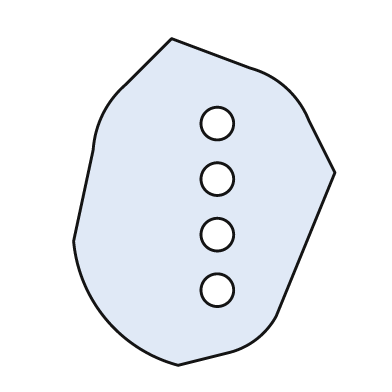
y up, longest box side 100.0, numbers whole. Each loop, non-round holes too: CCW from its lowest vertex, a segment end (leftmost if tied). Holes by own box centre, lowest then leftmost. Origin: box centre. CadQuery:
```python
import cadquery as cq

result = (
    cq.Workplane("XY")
    .moveTo(-8.0, -50.0)
    .lineTo(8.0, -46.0)
    .threePointArc((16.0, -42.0), (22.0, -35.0))
    .lineTo(40.0, 9.0)
    .lineTo(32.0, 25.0)
    .threePointArc((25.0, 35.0), (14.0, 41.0))
    .lineTo(-10.0, 50.0)
    .lineTo(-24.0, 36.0)
    .threePointArc((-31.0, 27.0), (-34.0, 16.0))
    .lineTo(-40.0, -12.0)
    .threePointArc((-30.0, -36.0), (-8.0, -50.0))
    .close()
    .moveTo(4.0, -27.0)
    .circle(5.0)
    .moveTo(4.0, -10.0)
    .circle(5.0)
    .moveTo(4.0, 7.0)
    .circle(5.0)
    .moveTo(4.0, 24.0)
    .circle(5.0)
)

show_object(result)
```